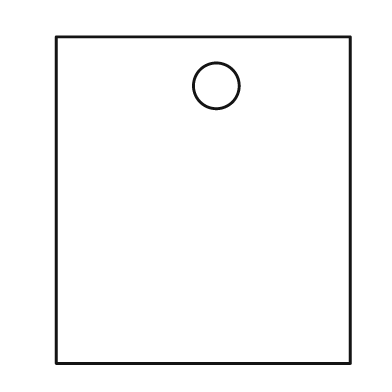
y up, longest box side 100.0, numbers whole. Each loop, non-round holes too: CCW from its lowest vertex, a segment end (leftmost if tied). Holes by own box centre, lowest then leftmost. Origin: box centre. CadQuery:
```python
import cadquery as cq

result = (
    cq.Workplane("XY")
    .moveTo(-45.0, -50.0)
    .lineTo(45.0, -50.0)
    .lineTo(45.0, 50.0)
    .lineTo(-45.0, 50.0)
    .close()
    .moveTo(4.0, 35.0)
    .circle(7.0)
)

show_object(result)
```